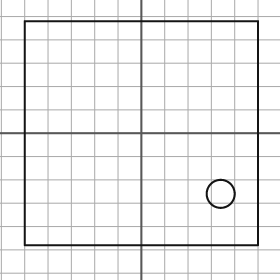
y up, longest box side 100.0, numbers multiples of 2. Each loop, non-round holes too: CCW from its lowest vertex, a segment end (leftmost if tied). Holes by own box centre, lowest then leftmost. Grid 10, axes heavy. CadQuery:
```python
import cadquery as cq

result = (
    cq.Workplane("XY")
    .moveTo(-50.0, -48.0)
    .lineTo(50.0, -48.0)
    .lineTo(50.0, 48.0)
    .lineTo(-50.0, 48.0)
    .close()
    .moveTo(34.0, -26.0)
    .circle(6.0)
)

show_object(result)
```